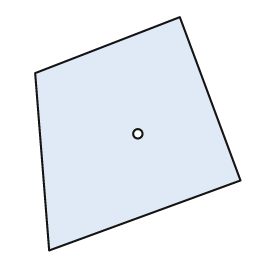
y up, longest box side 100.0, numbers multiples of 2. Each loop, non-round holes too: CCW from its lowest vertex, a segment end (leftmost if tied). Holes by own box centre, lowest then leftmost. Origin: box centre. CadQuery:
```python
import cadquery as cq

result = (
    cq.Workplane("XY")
    .moveTo(-38.0, -50.0)
    .lineTo(44.0, -20.0)
    .lineTo(18.0, 50.0)
    .lineTo(-44.0, 26.0)
    .close()
    .moveTo(0.0, 0.0)
    .circle(2.0)
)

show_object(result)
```